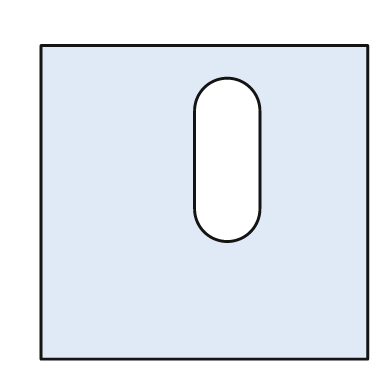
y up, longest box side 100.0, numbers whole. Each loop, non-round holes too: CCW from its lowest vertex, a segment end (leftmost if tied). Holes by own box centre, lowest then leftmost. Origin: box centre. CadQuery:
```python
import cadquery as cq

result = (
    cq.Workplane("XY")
    .moveTo(-50.0, -48.0)
    .lineTo(50.0, -48.0)
    .lineTo(50.0, 48.0)
    .lineTo(-50.0, 48.0)
    .close()
    .moveTo(-3.0, -2.0)
    .threePointArc((7.0, -12.0), (17.0, -2.0))
    .lineTo(17.0, 28.0)
    .threePointArc((7.0, 38.0), (-3.0, 28.0))
    .close()
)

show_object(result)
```